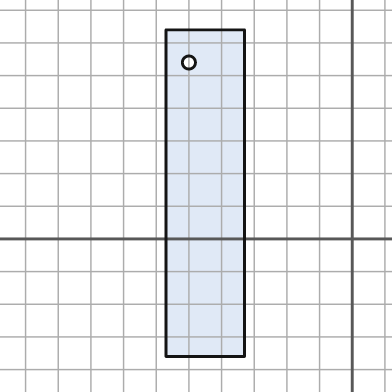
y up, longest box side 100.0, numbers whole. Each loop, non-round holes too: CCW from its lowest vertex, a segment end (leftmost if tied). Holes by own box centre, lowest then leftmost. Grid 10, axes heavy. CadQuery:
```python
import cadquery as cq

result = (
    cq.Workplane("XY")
    .moveTo(-57.0, -36.0)
    .lineTo(-33.0, -36.0)
    .lineTo(-33.0, 64.0)
    .lineTo(-57.0, 64.0)
    .close()
    .moveTo(-50.0, 54.0)
    .circle(2.0)
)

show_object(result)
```